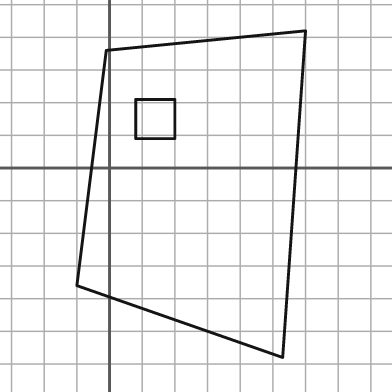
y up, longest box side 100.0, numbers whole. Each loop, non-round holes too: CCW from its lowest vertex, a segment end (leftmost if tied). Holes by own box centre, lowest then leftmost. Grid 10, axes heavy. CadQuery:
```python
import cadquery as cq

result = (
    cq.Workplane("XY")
    .moveTo(53.0, -58.0)
    .lineTo(60.0, 42.0)
    .lineTo(-1.0, 36.0)
    .lineTo(-10.0, -36.0)
    .close()
    .moveTo(8.0, 9.0)
    .lineTo(20.0, 9.0)
    .lineTo(20.0, 21.0)
    .lineTo(8.0, 21.0)
    .close()
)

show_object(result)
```